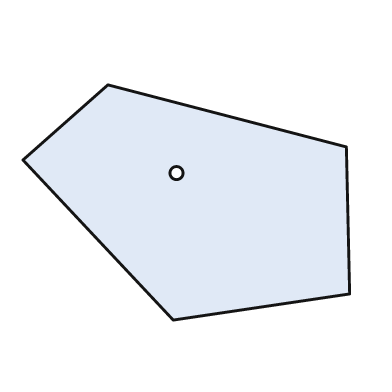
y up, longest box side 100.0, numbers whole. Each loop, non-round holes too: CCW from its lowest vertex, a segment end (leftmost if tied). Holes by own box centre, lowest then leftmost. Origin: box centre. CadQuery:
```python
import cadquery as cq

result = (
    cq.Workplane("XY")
    .moveTo(-4.0, -36.0)
    .lineTo(50.0, -28.0)
    .lineTo(49.0, 17.0)
    .lineTo(-24.0, 36.0)
    .lineTo(-50.0, 13.0)
    .close()
    .moveTo(-3.0, 9.0)
    .circle(2.0)
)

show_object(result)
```